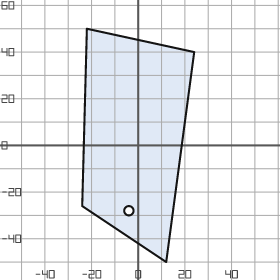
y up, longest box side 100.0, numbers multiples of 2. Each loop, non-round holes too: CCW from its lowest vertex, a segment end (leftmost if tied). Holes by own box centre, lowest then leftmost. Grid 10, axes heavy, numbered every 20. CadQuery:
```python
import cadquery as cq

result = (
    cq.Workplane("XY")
    .moveTo(12.0, -50.0)
    .lineTo(24.0, 40.0)
    .lineTo(-22.0, 50.0)
    .lineTo(-24.0, -26.0)
    .close()
    .moveTo(-4.0, -28.0)
    .circle(2.0)
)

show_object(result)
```